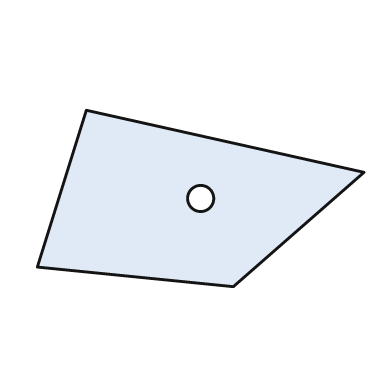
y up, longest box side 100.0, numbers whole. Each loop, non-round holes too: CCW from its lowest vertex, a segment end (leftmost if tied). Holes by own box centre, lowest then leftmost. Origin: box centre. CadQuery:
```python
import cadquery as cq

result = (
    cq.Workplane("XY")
    .moveTo(10.0, -27.0)
    .lineTo(50.0, 8.0)
    .lineTo(-35.0, 27.0)
    .lineTo(-50.0, -21.0)
    .close()
    .moveTo(0.0, 0.0)
    .circle(4.0)
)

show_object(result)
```